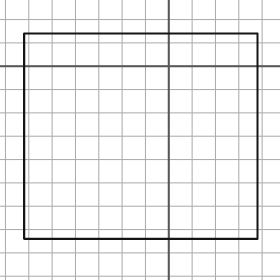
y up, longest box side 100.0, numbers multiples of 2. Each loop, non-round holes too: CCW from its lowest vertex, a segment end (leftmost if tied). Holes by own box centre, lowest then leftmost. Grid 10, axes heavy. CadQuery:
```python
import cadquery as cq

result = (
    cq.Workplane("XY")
    .moveTo(-62.0, -74.0)
    .lineTo(38.0, -74.0)
    .lineTo(38.0, 14.0)
    .lineTo(-62.0, 14.0)
    .close()
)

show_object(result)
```